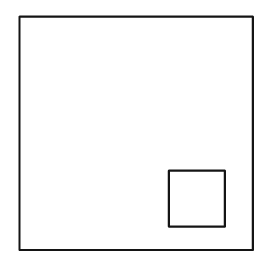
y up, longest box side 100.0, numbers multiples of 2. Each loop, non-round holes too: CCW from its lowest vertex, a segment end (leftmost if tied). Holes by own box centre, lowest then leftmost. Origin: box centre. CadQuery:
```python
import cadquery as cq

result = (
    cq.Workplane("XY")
    .moveTo(-50.0, -50.0)
    .lineTo(50.0, -50.0)
    .lineTo(50.0, 50.0)
    .lineTo(-50.0, 50.0)
    .close()
    .moveTo(14.0, -40.0)
    .lineTo(38.0, -40.0)
    .lineTo(38.0, -16.0)
    .lineTo(14.0, -16.0)
    .close()
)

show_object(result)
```